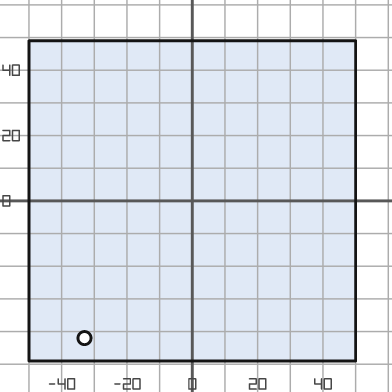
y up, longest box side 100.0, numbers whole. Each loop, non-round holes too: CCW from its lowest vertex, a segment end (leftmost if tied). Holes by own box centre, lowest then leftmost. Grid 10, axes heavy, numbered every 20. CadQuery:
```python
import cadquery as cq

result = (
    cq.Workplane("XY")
    .moveTo(-50.0, -49.0)
    .lineTo(50.0, -49.0)
    .lineTo(50.0, 49.0)
    .lineTo(-50.0, 49.0)
    .close()
    .moveTo(-33.0, -42.0)
    .circle(2.0)
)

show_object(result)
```